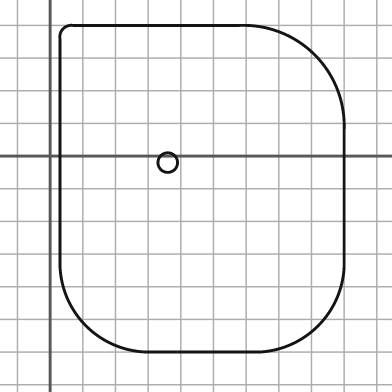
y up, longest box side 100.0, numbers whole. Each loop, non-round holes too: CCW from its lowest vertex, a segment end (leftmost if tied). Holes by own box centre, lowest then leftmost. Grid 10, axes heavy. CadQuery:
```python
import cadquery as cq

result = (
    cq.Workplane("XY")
    .moveTo(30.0, -60.0)
    .lineTo(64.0, -60.0)
    .threePointArc((82.0, -52.0), (90.0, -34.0))
    .lineTo(90.0, 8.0)
    .threePointArc((81.0, 31.0), (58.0, 40.0))
    .lineTo(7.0, 40.0)
    .threePointArc((4.0, 39.0), (3.0, 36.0))
    .lineTo(3.0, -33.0)
    .threePointArc((11.0, -52.0), (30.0, -60.0))
    .close()
    .moveTo(36.0, -2.0)
    .circle(3.0)
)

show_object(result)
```